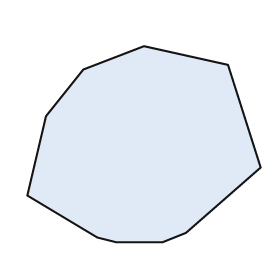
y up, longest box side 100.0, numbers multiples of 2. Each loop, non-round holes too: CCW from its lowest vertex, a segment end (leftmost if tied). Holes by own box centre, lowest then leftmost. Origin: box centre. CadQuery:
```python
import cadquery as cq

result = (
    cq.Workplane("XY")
    .moveTo(-12.0, -42.0)
    .lineTo(8.0, -42.0)
    .lineTo(18.0, -38.0)
    .lineTo(50.0, -10.0)
    .lineTo(36.0, 34.0)
    .lineTo(0.0, 42.0)
    .lineTo(-26.0, 32.0)
    .lineTo(-42.0, 12.0)
    .lineTo(-50.0, -22.0)
    .lineTo(-20.0, -40.0)
    .close()
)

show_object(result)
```